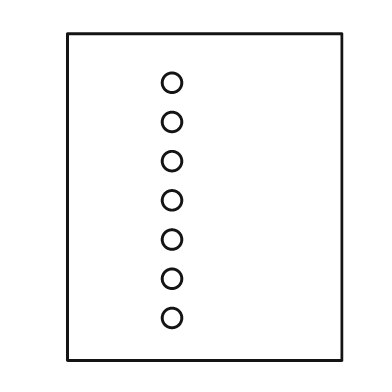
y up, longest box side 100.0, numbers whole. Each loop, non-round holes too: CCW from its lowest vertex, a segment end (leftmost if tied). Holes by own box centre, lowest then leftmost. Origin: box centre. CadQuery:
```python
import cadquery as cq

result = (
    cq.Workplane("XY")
    .moveTo(-42.0, -50.0)
    .lineTo(42.0, -50.0)
    .lineTo(42.0, 50.0)
    .lineTo(-42.0, 50.0)
    .close()
    .moveTo(-10.0, -37.0)
    .circle(3.0)
    .moveTo(-10.0, -25.0)
    .circle(3.0)
    .moveTo(-10.0, -13.0)
    .circle(3.0)
    .moveTo(-10.0, -1.0)
    .circle(3.0)
    .moveTo(-10.0, 11.0)
    .circle(3.0)
    .moveTo(-10.0, 23.0)
    .circle(3.0)
    .moveTo(-10.0, 35.0)
    .circle(3.0)
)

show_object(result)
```